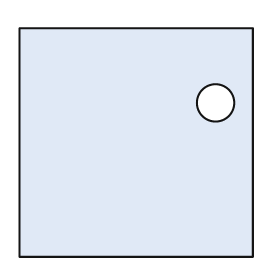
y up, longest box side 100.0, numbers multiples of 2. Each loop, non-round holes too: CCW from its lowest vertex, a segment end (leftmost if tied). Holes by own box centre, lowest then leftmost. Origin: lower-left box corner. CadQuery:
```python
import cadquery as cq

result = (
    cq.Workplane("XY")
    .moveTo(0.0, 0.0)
    .lineTo(100.0, 0.0)
    .lineTo(100.0, 98.0)
    .lineTo(0.0, 98.0)
    .close()
    .moveTo(84.0, 66.0)
    .circle(8.0)
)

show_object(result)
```